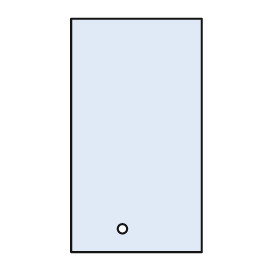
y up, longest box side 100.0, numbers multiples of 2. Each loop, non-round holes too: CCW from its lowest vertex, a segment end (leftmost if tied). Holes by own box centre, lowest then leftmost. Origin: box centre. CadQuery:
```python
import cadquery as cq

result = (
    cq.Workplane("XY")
    .moveTo(-28.0, -50.0)
    .lineTo(28.0, -50.0)
    .lineTo(28.0, 50.0)
    .lineTo(-28.0, 50.0)
    .close()
    .moveTo(-6.0, -40.0)
    .circle(2.0)
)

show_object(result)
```